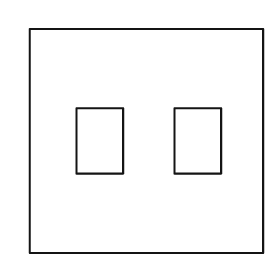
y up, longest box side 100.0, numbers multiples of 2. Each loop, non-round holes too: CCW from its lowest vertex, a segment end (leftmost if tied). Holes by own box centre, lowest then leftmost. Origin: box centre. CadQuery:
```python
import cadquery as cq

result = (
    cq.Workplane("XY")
    .moveTo(-50.0, -48.0)
    .lineTo(50.0, -48.0)
    .lineTo(50.0, 48.0)
    .lineTo(-50.0, 48.0)
    .close()
    .moveTo(-30.0, -14.0)
    .lineTo(-10.0, -14.0)
    .lineTo(-10.0, 14.0)
    .lineTo(-30.0, 14.0)
    .close()
    .moveTo(12.0, -14.0)
    .lineTo(32.0, -14.0)
    .lineTo(32.0, 14.0)
    .lineTo(12.0, 14.0)
    .close()
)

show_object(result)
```